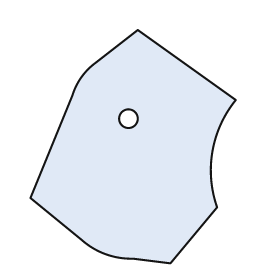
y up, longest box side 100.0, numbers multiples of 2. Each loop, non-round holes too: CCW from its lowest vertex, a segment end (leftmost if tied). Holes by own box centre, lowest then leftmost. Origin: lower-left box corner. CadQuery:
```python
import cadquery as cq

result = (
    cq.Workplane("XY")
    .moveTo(60.0, 0.0)
    .lineTo(80.0, 24.0)
    .threePointArc((78.0, 48.0), (88.0, 70.0))
    .lineTo(46.0, 100.0)
    .lineTo(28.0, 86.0)
    .threePointArc((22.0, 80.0), (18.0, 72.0))
    .lineTo(0.0, 28.0)
    .lineTo(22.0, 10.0)
    .threePointArc((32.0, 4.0), (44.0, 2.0))
    .close()
    .moveTo(42.0, 62.0)
    .circle(4.0)
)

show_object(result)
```